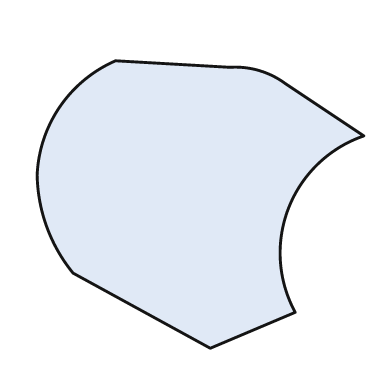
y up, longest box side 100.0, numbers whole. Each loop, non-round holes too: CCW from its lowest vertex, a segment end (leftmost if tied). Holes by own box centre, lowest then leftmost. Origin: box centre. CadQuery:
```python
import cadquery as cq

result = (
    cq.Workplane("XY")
    .moveTo(3.0, -44.0)
    .lineTo(29.0, -33.0)
    .threePointArc((27.0, -1.0), (50.0, 21.0))
    .lineTo(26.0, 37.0)
    .threePointArc((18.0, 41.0), (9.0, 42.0))
    .lineTo(-26.0, 44.0)
    .threePointArc((-43.0, 30.0), (-50.0, 9.0))
    .threePointArc((-47.0, -7.0), (-39.0, -21.0))
    .close()
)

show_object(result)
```